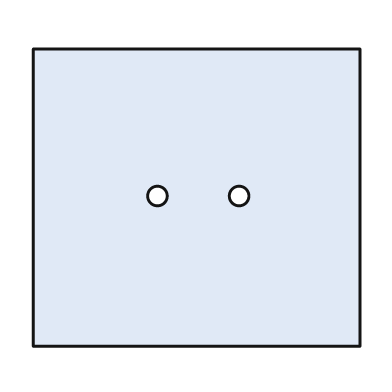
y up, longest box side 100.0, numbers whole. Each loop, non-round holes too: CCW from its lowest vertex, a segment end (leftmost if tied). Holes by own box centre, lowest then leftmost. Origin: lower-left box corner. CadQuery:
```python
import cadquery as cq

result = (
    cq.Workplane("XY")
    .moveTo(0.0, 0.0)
    .lineTo(100.0, 0.0)
    .lineTo(100.0, 91.0)
    .lineTo(0.0, 91.0)
    .close()
    .moveTo(38.0, 46.0)
    .circle(3.0)
    .moveTo(63.0, 46.0)
    .circle(3.0)
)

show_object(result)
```